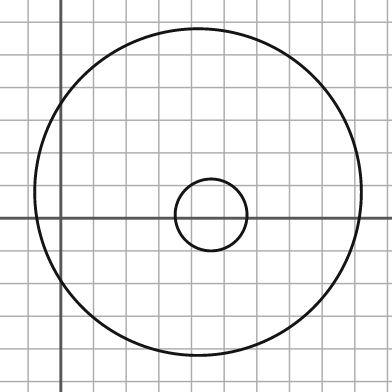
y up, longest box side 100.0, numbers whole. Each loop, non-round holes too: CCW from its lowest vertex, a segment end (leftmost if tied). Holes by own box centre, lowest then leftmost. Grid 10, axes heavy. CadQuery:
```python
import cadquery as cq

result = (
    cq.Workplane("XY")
    .moveTo(42.0, 8.0)
    .circle(50.0)
    .moveTo(46.0, 1.0)
    .circle(11.0)
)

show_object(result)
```